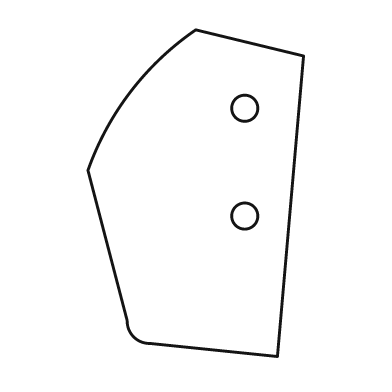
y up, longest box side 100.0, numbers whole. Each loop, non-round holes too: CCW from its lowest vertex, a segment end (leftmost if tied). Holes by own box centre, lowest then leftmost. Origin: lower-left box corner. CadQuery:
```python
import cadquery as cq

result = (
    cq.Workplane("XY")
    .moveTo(58.0, 0.0)
    .lineTo(66.0, 92.0)
    .lineTo(33.0, 100.0)
    .threePointArc((13.0, 81.0), (0.0, 57.0))
    .lineTo(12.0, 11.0)
    .threePointArc((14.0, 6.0), (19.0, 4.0))
    .close()
    .moveTo(48.0, 43.0)
    .circle(4.0)
    .moveTo(48.0, 76.0)
    .circle(4.0)
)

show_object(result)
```